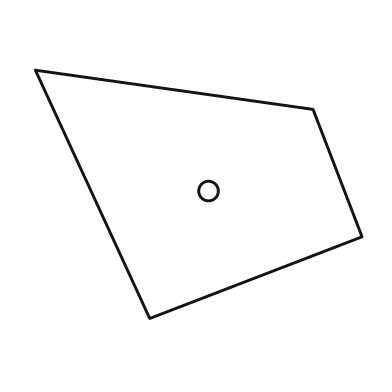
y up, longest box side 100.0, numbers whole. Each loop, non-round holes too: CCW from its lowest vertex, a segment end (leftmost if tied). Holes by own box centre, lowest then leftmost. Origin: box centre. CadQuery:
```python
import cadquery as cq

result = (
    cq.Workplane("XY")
    .moveTo(-15.0, -38.0)
    .lineTo(50.0, -13.0)
    .lineTo(35.0, 26.0)
    .lineTo(-50.0, 38.0)
    .close()
    .moveTo(3.0, 1.0)
    .circle(3.0)
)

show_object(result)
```